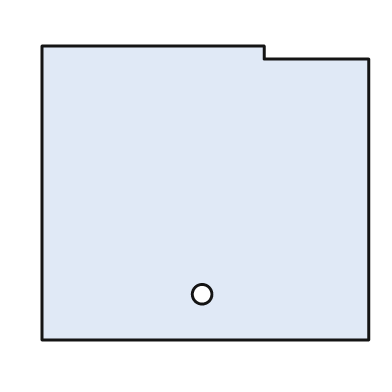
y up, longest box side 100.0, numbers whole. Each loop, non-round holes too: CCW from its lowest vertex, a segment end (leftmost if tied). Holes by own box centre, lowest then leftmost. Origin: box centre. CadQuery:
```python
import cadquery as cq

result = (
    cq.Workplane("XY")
    .moveTo(-50.0, -45.0)
    .lineTo(50.0, -45.0)
    .lineTo(50.0, 41.0)
    .lineTo(18.0, 41.0)
    .lineTo(18.0, 45.0)
    .lineTo(-50.0, 45.0)
    .close()
    .moveTo(-1.0, -31.0)
    .circle(3.0)
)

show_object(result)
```